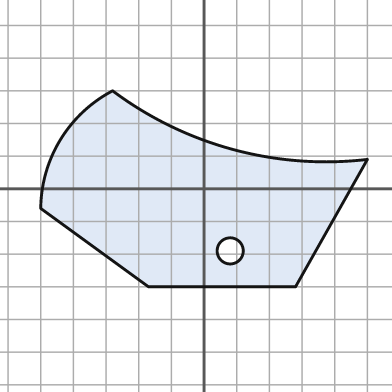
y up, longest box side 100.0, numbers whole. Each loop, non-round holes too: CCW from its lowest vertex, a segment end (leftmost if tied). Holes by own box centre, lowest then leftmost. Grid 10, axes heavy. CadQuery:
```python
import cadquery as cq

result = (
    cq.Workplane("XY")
    .moveTo(-17.0, -30.0)
    .lineTo(28.0, -30.0)
    .lineTo(50.0, 9.0)
    .threePointArc((9.0, 12.0), (-28.0, 30.0))
    .threePointArc((-44.0, 15.0), (-50.0, -6.0))
    .close()
    .moveTo(8.0, -19.0)
    .circle(4.0)
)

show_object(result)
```